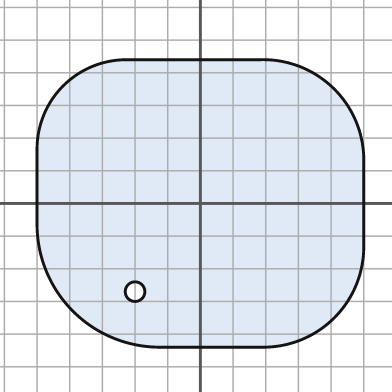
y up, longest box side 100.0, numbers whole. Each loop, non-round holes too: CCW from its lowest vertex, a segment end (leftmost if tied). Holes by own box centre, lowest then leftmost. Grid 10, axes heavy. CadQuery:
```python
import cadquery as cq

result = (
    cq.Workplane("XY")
    .moveTo(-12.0, -44.0)
    .lineTo(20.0, -44.0)
    .threePointArc((41.0, -35.0), (50.0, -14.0))
    .lineTo(50.0, 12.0)
    .threePointArc((41.0, 35.0), (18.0, 44.0))
    .lineTo(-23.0, 44.0)
    .threePointArc((-42.0, 36.0), (-50.0, 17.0))
    .lineTo(-50.0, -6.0)
    .threePointArc((-39.0, -33.0), (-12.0, -44.0))
    .close()
    .moveTo(-20.0, -27.0)
    .circle(3.0)
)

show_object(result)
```